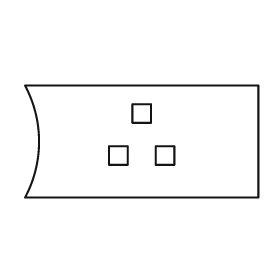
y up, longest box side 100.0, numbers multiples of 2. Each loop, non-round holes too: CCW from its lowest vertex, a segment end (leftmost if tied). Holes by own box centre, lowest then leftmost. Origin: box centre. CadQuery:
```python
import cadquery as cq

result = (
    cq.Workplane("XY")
    .moveTo(-50.0, -24.0)
    .lineTo(50.0, -24.0)
    .lineTo(50.0, 24.0)
    .lineTo(-50.0, 24.0)
    .threePointArc((-44.0, 0.0), (-50.0, -24.0))
    .close()
    .moveTo(-14.0, -10.0)
    .lineTo(-6.0, -10.0)
    .lineTo(-6.0, -2.0)
    .lineTo(-14.0, -2.0)
    .close()
    .moveTo(6.0, -10.0)
    .lineTo(14.0, -10.0)
    .lineTo(14.0, -2.0)
    .lineTo(6.0, -2.0)
    .close()
    .moveTo(-4.0, 8.0)
    .lineTo(4.0, 8.0)
    .lineTo(4.0, 16.0)
    .lineTo(-4.0, 16.0)
    .close()
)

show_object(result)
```